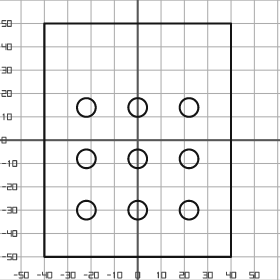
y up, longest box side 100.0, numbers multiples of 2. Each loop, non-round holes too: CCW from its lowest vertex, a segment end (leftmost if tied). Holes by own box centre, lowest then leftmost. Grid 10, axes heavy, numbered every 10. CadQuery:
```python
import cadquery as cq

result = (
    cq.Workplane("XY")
    .moveTo(-40.0, -50.0)
    .lineTo(40.0, -50.0)
    .lineTo(40.0, 50.0)
    .lineTo(-40.0, 50.0)
    .close()
    .moveTo(-22.0, -30.0)
    .circle(4.0)
    .moveTo(0.0, -30.0)
    .circle(4.0)
    .moveTo(22.0, -30.0)
    .circle(4.0)
    .moveTo(-22.0, -8.0)
    .circle(4.0)
    .moveTo(0.0, -8.0)
    .circle(4.0)
    .moveTo(22.0, -8.0)
    .circle(4.0)
    .moveTo(-22.0, 14.0)
    .circle(4.0)
    .moveTo(0.0, 14.0)
    .circle(4.0)
    .moveTo(22.0, 14.0)
    .circle(4.0)
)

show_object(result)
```